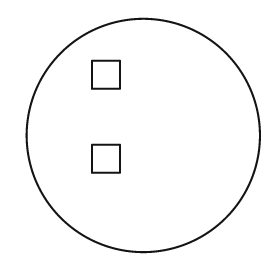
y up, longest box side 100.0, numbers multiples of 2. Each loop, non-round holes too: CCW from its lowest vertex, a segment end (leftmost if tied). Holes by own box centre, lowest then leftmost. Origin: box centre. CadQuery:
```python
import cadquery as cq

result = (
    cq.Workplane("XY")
    .moveTo(0.0, 0.0)
    .circle(50.0)
    .moveTo(-22.0, -16.0)
    .lineTo(-10.0, -16.0)
    .lineTo(-10.0, -4.0)
    .lineTo(-22.0, -4.0)
    .close()
    .moveTo(-22.0, 20.0)
    .lineTo(-10.0, 20.0)
    .lineTo(-10.0, 32.0)
    .lineTo(-22.0, 32.0)
    .close()
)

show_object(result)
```